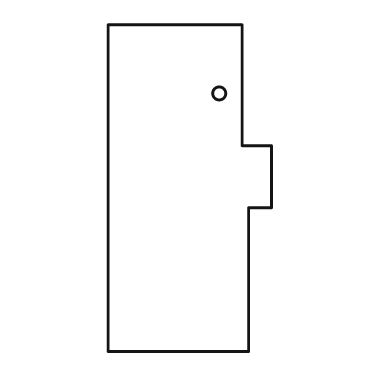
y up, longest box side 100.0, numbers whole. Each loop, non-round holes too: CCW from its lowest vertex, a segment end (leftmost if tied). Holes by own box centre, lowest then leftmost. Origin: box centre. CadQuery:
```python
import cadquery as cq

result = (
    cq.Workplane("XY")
    .moveTo(-25.0, -50.0)
    .lineTo(18.0, -50.0)
    .lineTo(18.0, -6.0)
    .lineTo(25.0, -6.0)
    .lineTo(25.0, 13.0)
    .lineTo(16.0, 13.0)
    .lineTo(16.0, 50.0)
    .lineTo(-25.0, 50.0)
    .close()
    .moveTo(9.0, 29.0)
    .circle(2.0)
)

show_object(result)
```